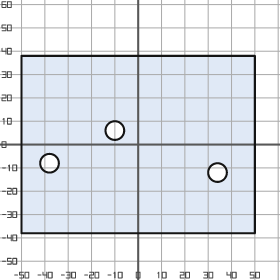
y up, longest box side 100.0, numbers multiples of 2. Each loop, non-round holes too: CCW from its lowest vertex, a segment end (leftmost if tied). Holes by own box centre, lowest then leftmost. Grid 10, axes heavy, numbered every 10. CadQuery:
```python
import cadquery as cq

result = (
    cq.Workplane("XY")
    .moveTo(-50.0, -38.0)
    .lineTo(50.0, -38.0)
    .lineTo(50.0, 38.0)
    .lineTo(-50.0, 38.0)
    .close()
    .moveTo(34.0, -12.0)
    .circle(4.0)
    .moveTo(-38.0, -8.0)
    .circle(4.0)
    .moveTo(-10.0, 6.0)
    .circle(4.0)
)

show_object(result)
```